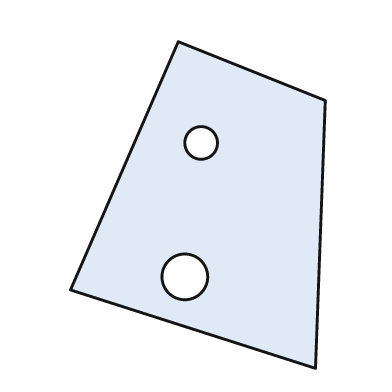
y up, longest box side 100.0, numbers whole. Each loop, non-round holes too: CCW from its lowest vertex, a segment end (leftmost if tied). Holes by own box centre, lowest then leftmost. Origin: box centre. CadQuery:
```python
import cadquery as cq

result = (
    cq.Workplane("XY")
    .moveTo(36.0, -50.0)
    .lineTo(39.0, 32.0)
    .lineTo(-6.0, 50.0)
    .lineTo(-39.0, -26.0)
    .close()
    .moveTo(-4.0, -22.0)
    .circle(7.0)
    .moveTo(1.0, 19.0)
    .circle(5.0)
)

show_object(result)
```